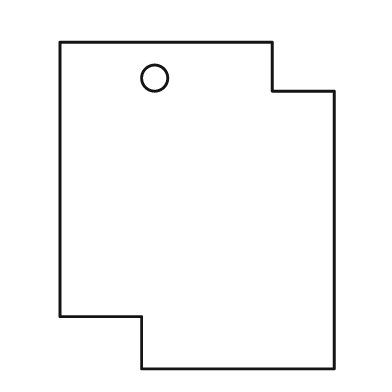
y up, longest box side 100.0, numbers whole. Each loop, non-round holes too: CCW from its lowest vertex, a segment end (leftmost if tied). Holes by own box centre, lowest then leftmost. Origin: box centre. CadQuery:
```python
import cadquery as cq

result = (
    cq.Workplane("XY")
    .moveTo(-17.0, -50.0)
    .lineTo(42.0, -50.0)
    .lineTo(42.0, 35.0)
    .lineTo(23.0, 35.0)
    .lineTo(23.0, 50.0)
    .lineTo(-42.0, 50.0)
    .lineTo(-42.0, -34.0)
    .lineTo(-17.0, -34.0)
    .close()
    .moveTo(-13.0, 39.0)
    .circle(4.0)
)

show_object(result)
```